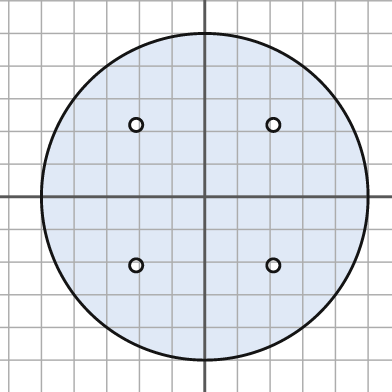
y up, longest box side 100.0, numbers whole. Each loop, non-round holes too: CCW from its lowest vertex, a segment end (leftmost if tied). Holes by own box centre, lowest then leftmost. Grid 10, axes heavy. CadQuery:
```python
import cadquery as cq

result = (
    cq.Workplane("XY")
    .moveTo(0.0, 0.0)
    .circle(50.0)
    .moveTo(-21.0, -21.0)
    .circle(2.0)
    .moveTo(21.0, -21.0)
    .circle(2.0)
    .moveTo(-21.0, 22.0)
    .circle(2.0)
    .moveTo(21.0, 22.0)
    .circle(2.0)
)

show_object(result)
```